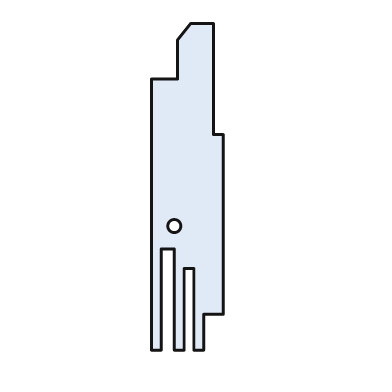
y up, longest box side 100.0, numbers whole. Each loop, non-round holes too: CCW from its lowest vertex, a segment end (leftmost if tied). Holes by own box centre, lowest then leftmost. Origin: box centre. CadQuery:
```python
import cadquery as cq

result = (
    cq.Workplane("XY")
    .moveTo(-11.0, -50.0)
    .lineTo(-8.0, -50.0)
    .lineTo(-8.0, -19.0)
    .lineTo(-4.0, -19.0)
    .lineTo(-4.0, -50.0)
    .lineTo(-1.0, -50.0)
    .lineTo(-1.0, -25.0)
    .lineTo(2.0, -25.0)
    .lineTo(2.0, -50.0)
    .lineTo(5.0, -50.0)
    .lineTo(5.0, -39.0)
    .lineTo(11.0, -39.0)
    .lineTo(11.0, 16.0)
    .lineTo(8.0, 16.0)
    .lineTo(8.0, 50.0)
    .lineTo(1.0, 50.0)
    .lineTo(-3.0, 45.0)
    .lineTo(-3.0, 33.0)
    .lineTo(-11.0, 33.0)
    .close()
    .moveTo(-4.0, -12.0)
    .circle(2.0)
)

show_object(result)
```